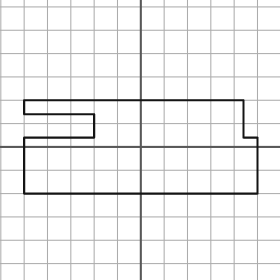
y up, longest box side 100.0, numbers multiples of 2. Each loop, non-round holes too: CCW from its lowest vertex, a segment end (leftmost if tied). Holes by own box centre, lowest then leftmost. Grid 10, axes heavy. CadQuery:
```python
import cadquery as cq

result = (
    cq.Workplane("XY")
    .moveTo(-50.0, -20.0)
    .lineTo(50.0, -20.0)
    .lineTo(50.0, 4.0)
    .lineTo(44.0, 4.0)
    .lineTo(44.0, 20.0)
    .lineTo(-50.0, 20.0)
    .lineTo(-50.0, 14.0)
    .lineTo(-20.0, 14.0)
    .lineTo(-20.0, 4.0)
    .lineTo(-50.0, 4.0)
    .close()
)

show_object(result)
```